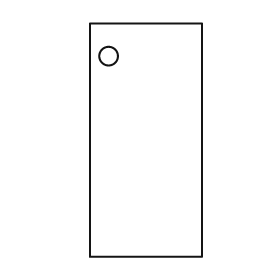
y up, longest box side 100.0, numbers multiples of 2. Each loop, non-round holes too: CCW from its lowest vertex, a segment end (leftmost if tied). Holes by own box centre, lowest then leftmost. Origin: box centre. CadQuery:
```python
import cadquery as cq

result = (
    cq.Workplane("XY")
    .moveTo(-24.0, -50.0)
    .lineTo(24.0, -50.0)
    .lineTo(24.0, 50.0)
    .lineTo(-24.0, 50.0)
    .close()
    .moveTo(-16.0, 36.0)
    .circle(4.0)
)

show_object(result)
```